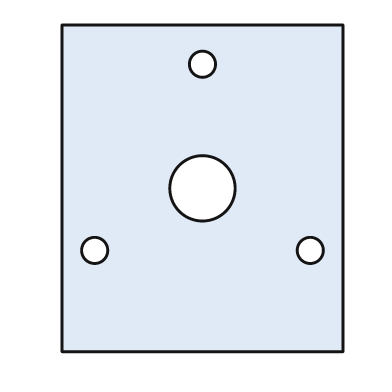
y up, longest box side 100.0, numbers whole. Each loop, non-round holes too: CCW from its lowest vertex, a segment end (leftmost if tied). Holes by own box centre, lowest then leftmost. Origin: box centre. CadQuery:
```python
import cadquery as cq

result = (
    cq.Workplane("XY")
    .moveTo(-43.0, -50.0)
    .lineTo(43.0, -50.0)
    .lineTo(43.0, 50.0)
    .lineTo(-43.0, 50.0)
    .close()
    .moveTo(-33.0, -19.0)
    .circle(4.0)
    .moveTo(33.0, -19.0)
    .circle(4.0)
    .moveTo(0.0, 0.0)
    .circle(10.0)
    .moveTo(0.0, 38.0)
    .circle(4.0)
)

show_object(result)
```